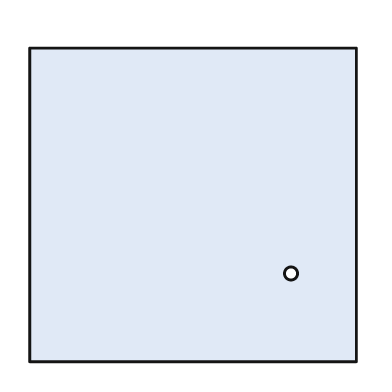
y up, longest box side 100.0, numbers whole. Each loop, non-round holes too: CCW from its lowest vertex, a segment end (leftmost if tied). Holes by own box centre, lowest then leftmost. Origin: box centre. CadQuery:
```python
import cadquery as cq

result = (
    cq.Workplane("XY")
    .moveTo(-50.0, -48.0)
    .lineTo(50.0, -48.0)
    .lineTo(50.0, 48.0)
    .lineTo(-50.0, 48.0)
    .close()
    .moveTo(30.0, -21.0)
    .circle(2.0)
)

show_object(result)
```